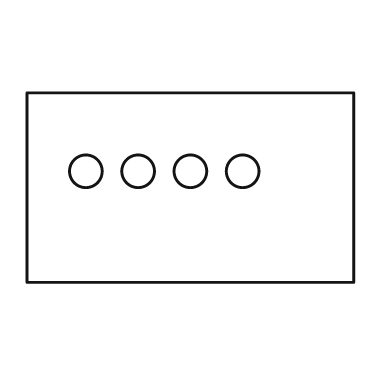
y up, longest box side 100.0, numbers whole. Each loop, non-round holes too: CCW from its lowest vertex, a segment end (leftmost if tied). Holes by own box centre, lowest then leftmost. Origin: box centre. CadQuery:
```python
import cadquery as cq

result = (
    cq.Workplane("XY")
    .moveTo(-50.0, -29.0)
    .lineTo(50.0, -29.0)
    .lineTo(50.0, 29.0)
    .lineTo(-50.0, 29.0)
    .close()
    .moveTo(-32.0, 5.0)
    .circle(5.0)
    .moveTo(-16.0, 5.0)
    .circle(5.0)
    .moveTo(0.0, 5.0)
    .circle(5.0)
    .moveTo(16.0, 5.0)
    .circle(5.0)
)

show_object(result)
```